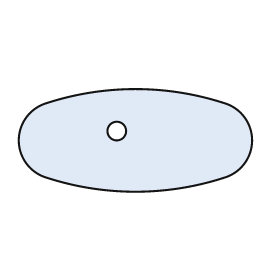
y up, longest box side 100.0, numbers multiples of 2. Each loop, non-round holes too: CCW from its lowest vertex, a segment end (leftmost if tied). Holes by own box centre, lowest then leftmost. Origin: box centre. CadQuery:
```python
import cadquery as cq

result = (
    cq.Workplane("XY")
    .moveTo(-38.0, -16.0)
    .threePointArc((0.0, -22.0), (38.0, -16.0))
    .threePointArc((50.0, 0.0), (38.0, 16.0))
    .threePointArc((0.0, 22.0), (-38.0, 16.0))
    .threePointArc((-50.0, 0.0), (-38.0, -16.0))
    .close()
    .moveTo(-8.0, 4.0)
    .circle(4.0)
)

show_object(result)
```